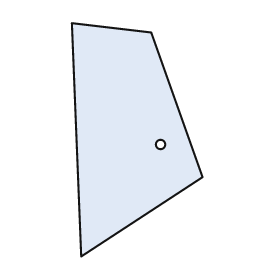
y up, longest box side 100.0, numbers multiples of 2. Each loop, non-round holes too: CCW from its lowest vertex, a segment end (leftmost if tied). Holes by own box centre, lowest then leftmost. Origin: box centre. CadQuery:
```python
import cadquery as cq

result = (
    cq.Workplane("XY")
    .moveTo(-24.0, -50.0)
    .lineTo(28.0, -16.0)
    .lineTo(6.0, 46.0)
    .lineTo(-28.0, 50.0)
    .close()
    .moveTo(10.0, -2.0)
    .circle(2.0)
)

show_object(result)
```